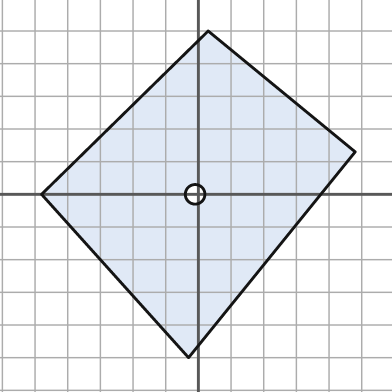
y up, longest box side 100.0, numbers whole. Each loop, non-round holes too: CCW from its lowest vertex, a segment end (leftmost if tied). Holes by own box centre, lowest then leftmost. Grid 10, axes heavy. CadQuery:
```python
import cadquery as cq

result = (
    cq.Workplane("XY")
    .moveTo(-3.0, -50.0)
    .lineTo(48.0, 13.0)
    .lineTo(3.0, 50.0)
    .lineTo(-48.0, 0.0)
    .close()
    .moveTo(-1.0, 0.0)
    .circle(3.0)
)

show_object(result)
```